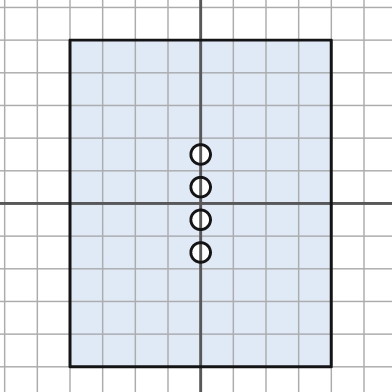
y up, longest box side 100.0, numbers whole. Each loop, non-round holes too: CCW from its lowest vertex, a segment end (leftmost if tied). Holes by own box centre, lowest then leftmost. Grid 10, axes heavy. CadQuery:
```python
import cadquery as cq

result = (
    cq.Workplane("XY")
    .moveTo(-40.0, -50.0)
    .lineTo(40.0, -50.0)
    .lineTo(40.0, 50.0)
    .lineTo(-40.0, 50.0)
    .close()
    .moveTo(0.0, -15.0)
    .circle(3.0)
    .moveTo(0.0, -5.0)
    .circle(3.0)
    .moveTo(0.0, 5.0)
    .circle(3.0)
    .moveTo(0.0, 15.0)
    .circle(3.0)
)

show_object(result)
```